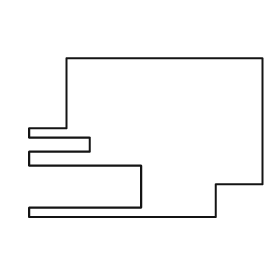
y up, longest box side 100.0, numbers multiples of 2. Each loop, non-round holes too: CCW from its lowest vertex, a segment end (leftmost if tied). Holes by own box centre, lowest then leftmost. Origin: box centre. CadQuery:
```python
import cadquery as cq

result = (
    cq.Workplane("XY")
    .moveTo(-50.0, -34.0)
    .lineTo(30.0, -34.0)
    .lineTo(30.0, -20.0)
    .lineTo(50.0, -20.0)
    .lineTo(50.0, 34.0)
    .lineTo(-34.0, 34.0)
    .lineTo(-34.0, 4.0)
    .lineTo(-50.0, 4.0)
    .lineTo(-50.0, 0.0)
    .lineTo(-24.0, 0.0)
    .lineTo(-24.0, -6.0)
    .lineTo(-50.0, -6.0)
    .lineTo(-50.0, -12.0)
    .lineTo(-2.0, -12.0)
    .lineTo(-2.0, -30.0)
    .lineTo(-50.0, -30.0)
    .close()
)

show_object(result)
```